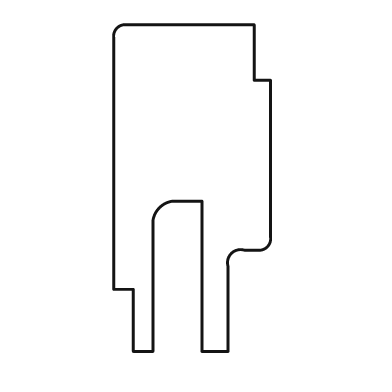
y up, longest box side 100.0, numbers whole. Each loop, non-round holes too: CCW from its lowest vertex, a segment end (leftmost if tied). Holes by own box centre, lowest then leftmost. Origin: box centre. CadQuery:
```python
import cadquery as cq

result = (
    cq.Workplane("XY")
    .moveTo(-18.0, -50.0)
    .lineTo(-12.0, -50.0)
    .lineTo(-12.0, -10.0)
    .threePointArc((-10.0, -6.0), (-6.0, -4.0))
    .lineTo(3.0, -4.0)
    .lineTo(3.0, -50.0)
    .lineTo(11.0, -50.0)
    .lineTo(11.0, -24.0)
    .threePointArc((12.0, -20.0), (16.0, -19.0))
    .lineTo(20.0, -19.0)
    .threePointArc((23.0, -18.0), (24.0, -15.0))
    .lineTo(24.0, 33.0)
    .lineTo(19.0, 33.0)
    .lineTo(19.0, 50.0)
    .lineTo(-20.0, 50.0)
    .threePointArc((-23.0, 49.0), (-24.0, 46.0))
    .lineTo(-24.0, -31.0)
    .lineTo(-18.0, -31.0)
    .close()
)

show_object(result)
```